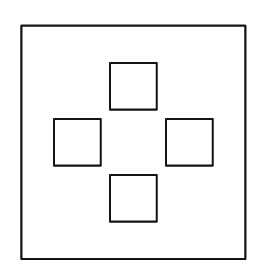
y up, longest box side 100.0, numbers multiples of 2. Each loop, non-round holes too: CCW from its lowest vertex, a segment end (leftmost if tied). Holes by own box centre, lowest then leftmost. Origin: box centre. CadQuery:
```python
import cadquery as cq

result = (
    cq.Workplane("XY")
    .moveTo(-48.0, -50.0)
    .lineTo(48.0, -50.0)
    .lineTo(48.0, 50.0)
    .lineTo(-48.0, 50.0)
    .close()
    .moveTo(-10.0, -34.0)
    .lineTo(10.0, -34.0)
    .lineTo(10.0, -14.0)
    .lineTo(-10.0, -14.0)
    .close()
    .moveTo(-34.0, -10.0)
    .lineTo(-14.0, -10.0)
    .lineTo(-14.0, 10.0)
    .lineTo(-34.0, 10.0)
    .close()
    .moveTo(14.0, -10.0)
    .lineTo(34.0, -10.0)
    .lineTo(34.0, 10.0)
    .lineTo(14.0, 10.0)
    .close()
    .moveTo(-10.0, 14.0)
    .lineTo(10.0, 14.0)
    .lineTo(10.0, 34.0)
    .lineTo(-10.0, 34.0)
    .close()
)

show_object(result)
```